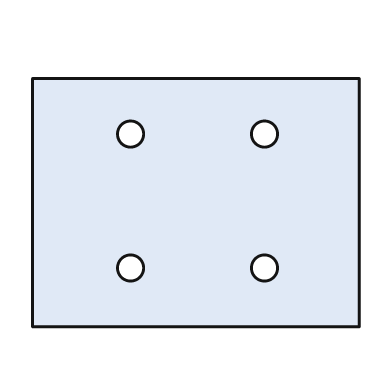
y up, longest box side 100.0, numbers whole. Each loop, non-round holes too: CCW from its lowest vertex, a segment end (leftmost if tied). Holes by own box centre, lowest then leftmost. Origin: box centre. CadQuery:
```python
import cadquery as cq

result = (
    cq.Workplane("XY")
    .moveTo(-50.0, -38.0)
    .lineTo(50.0, -38.0)
    .lineTo(50.0, 38.0)
    .lineTo(-50.0, 38.0)
    .close()
    .moveTo(-20.0, -20.0)
    .circle(4.0)
    .moveTo(21.0, -20.0)
    .circle(4.0)
    .moveTo(-20.0, 21.0)
    .circle(4.0)
    .moveTo(21.0, 21.0)
    .circle(4.0)
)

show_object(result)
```